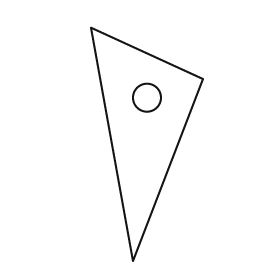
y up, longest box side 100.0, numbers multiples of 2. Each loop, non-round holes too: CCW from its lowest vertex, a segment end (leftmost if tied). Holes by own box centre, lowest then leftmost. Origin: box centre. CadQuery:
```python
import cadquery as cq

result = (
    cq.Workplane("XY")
    .moveTo(-6.0, -50.0)
    .lineTo(24.0, 28.0)
    .lineTo(-24.0, 50.0)
    .close()
    .moveTo(0.0, 20.0)
    .circle(6.0)
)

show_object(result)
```